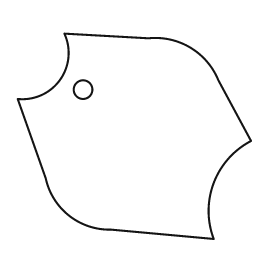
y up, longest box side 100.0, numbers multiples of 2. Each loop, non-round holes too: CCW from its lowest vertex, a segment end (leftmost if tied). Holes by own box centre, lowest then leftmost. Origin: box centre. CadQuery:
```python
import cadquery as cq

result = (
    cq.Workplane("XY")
    .moveTo(34.0, -44.0)
    .threePointArc((34.0, -20.0), (50.0, -2.0))
    .lineTo(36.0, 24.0)
    .threePointArc((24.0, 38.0), (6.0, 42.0))
    .lineTo(-30.0, 44.0)
    .threePointArc((-32.0, 24.0), (-50.0, 16.0))
    .lineTo(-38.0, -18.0)
    .threePointArc((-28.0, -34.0), (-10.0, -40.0))
    .close()
    .moveTo(-22.0, 20.0)
    .circle(4.0)
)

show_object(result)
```